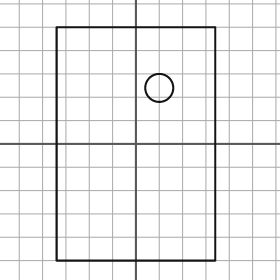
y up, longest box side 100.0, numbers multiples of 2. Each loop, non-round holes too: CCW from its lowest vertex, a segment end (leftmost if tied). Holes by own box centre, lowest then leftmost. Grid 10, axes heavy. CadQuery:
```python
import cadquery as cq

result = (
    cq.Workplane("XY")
    .moveTo(-34.0, -50.0)
    .lineTo(34.0, -50.0)
    .lineTo(34.0, 50.0)
    .lineTo(-34.0, 50.0)
    .close()
    .moveTo(10.0, 24.0)
    .circle(6.0)
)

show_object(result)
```